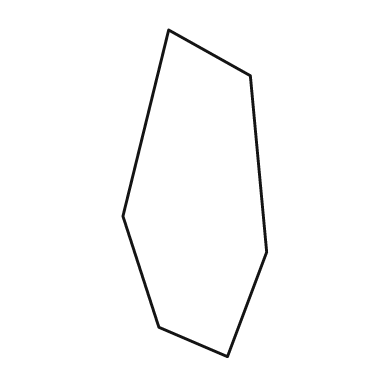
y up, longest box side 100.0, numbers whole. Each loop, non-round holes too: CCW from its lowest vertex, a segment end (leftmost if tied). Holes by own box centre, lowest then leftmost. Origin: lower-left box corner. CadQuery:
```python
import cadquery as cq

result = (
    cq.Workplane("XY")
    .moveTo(32.0, 0.0)
    .lineTo(44.0, 32.0)
    .lineTo(39.0, 86.0)
    .lineTo(14.0, 100.0)
    .lineTo(0.0, 43.0)
    .lineTo(11.0, 9.0)
    .close()
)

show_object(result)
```